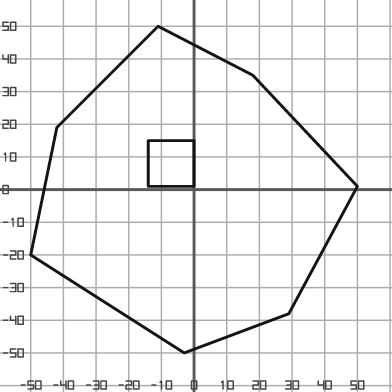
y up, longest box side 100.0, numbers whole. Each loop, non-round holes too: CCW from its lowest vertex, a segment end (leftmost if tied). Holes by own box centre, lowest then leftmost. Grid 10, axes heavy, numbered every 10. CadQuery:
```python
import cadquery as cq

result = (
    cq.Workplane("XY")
    .moveTo(-3.0, -50.0)
    .lineTo(29.0, -38.0)
    .lineTo(50.0, 1.0)
    .lineTo(18.0, 35.0)
    .lineTo(-11.0, 50.0)
    .lineTo(-42.0, 19.0)
    .lineTo(-50.0, -20.0)
    .close()
    .moveTo(-14.0, 1.0)
    .lineTo(0.0, 1.0)
    .lineTo(0.0, 15.0)
    .lineTo(-14.0, 15.0)
    .close()
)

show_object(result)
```